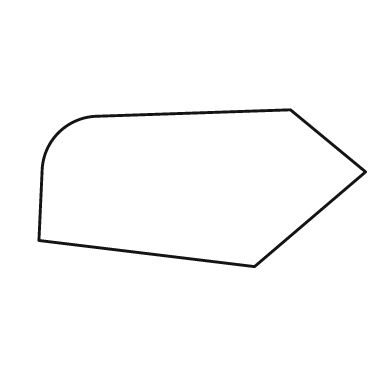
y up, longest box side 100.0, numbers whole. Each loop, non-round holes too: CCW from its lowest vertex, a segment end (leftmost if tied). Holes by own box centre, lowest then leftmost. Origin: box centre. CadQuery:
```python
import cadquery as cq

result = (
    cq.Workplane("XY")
    .moveTo(16.0, -24.0)
    .lineTo(50.0, 5.0)
    .lineTo(27.0, 24.0)
    .lineTo(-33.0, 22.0)
    .threePointArc((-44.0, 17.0), (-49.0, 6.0))
    .lineTo(-50.0, -16.0)
    .close()
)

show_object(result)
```